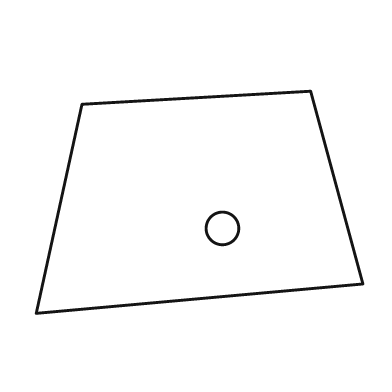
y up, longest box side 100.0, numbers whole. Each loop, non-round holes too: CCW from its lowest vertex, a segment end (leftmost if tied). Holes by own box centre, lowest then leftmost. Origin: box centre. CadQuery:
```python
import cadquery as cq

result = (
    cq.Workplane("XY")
    .moveTo(-50.0, -34.0)
    .lineTo(50.0, -25.0)
    .lineTo(34.0, 34.0)
    .lineTo(-36.0, 30.0)
    .close()
    .moveTo(7.0, -8.0)
    .circle(5.0)
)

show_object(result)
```